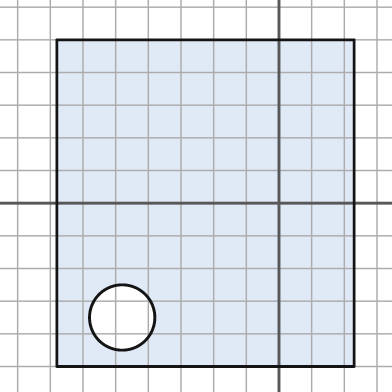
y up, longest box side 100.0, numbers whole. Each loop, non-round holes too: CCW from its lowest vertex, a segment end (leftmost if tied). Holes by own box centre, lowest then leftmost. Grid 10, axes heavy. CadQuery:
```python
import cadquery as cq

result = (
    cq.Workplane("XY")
    .moveTo(-68.0, -50.0)
    .lineTo(23.0, -50.0)
    .lineTo(23.0, 50.0)
    .lineTo(-68.0, 50.0)
    .close()
    .moveTo(-48.0, -35.0)
    .circle(10.0)
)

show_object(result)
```